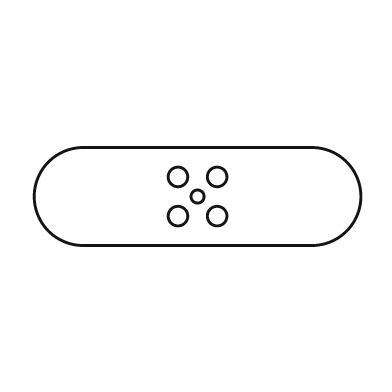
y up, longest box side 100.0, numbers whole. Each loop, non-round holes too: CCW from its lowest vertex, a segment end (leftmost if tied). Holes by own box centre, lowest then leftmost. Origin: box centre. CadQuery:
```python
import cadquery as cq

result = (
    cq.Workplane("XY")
    .moveTo(-35.0, -15.0)
    .lineTo(35.0, -15.0)
    .threePointArc((50.0, 0.0), (35.0, 15.0))
    .lineTo(-35.0, 15.0)
    .threePointArc((-50.0, 0.0), (-35.0, -15.0))
    .close()
    .moveTo(-6.0, -6.0)
    .circle(3.0)
    .moveTo(6.0, -6.0)
    .circle(3.0)
    .moveTo(0.0, 0.0)
    .circle(2.0)
    .moveTo(-6.0, 6.0)
    .circle(3.0)
    .moveTo(6.0, 6.0)
    .circle(3.0)
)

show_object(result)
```